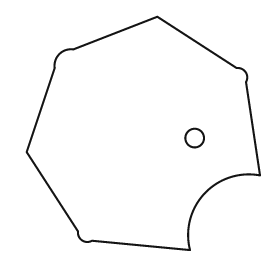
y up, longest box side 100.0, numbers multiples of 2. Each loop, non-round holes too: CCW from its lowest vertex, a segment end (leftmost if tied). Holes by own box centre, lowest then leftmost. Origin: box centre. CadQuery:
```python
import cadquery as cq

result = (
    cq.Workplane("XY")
    .moveTo(20.0, -50.0)
    .threePointArc((26.0, -26.0), (50.0, -18.0))
    .lineTo(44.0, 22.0)
    .threePointArc((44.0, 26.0), (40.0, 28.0))
    .lineTo(6.0, 50.0)
    .lineTo(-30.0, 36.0)
    .threePointArc((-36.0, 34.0), (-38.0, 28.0))
    .lineTo(-50.0, -8.0)
    .lineTo(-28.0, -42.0)
    .threePointArc((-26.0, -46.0), (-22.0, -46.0))
    .close()
    .moveTo(22.0, -2.0)
    .circle(4.0)
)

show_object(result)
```